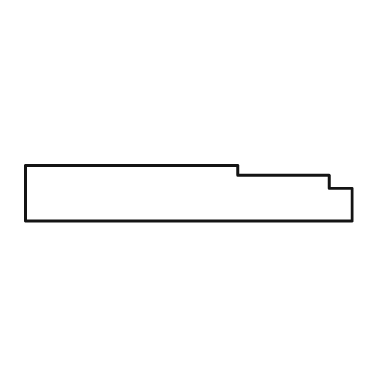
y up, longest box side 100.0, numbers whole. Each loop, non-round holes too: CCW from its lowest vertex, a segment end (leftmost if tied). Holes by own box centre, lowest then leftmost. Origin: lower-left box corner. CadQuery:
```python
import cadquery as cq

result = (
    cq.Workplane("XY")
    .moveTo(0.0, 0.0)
    .lineTo(100.0, 0.0)
    .lineTo(100.0, 10.0)
    .lineTo(93.0, 10.0)
    .lineTo(93.0, 14.0)
    .lineTo(65.0, 14.0)
    .lineTo(65.0, 17.0)
    .lineTo(0.0, 17.0)
    .close()
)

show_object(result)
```